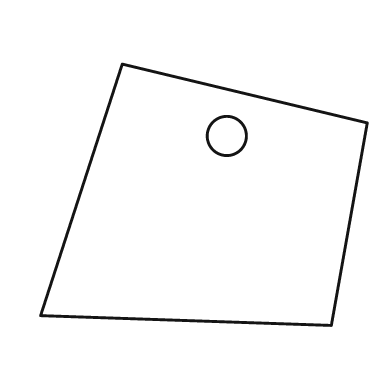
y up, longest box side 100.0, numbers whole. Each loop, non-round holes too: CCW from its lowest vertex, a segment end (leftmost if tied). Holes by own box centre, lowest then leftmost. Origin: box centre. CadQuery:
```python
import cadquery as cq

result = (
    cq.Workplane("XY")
    .moveTo(39.0, -40.0)
    .lineTo(50.0, 22.0)
    .lineTo(-25.0, 40.0)
    .lineTo(-50.0, -37.0)
    .close()
    .moveTo(7.0, 18.0)
    .circle(6.0)
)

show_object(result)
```